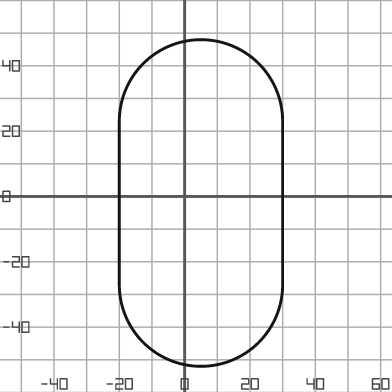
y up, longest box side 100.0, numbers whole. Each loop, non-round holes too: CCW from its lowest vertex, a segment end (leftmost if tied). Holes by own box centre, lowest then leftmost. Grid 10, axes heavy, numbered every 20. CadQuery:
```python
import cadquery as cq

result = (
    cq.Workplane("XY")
    .moveTo(-20.0, -27.0)
    .threePointArc((5.0, -52.0), (30.0, -27.0))
    .lineTo(30.0, 23.0)
    .threePointArc((5.0, 48.0), (-20.0, 23.0))
    .close()
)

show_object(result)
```